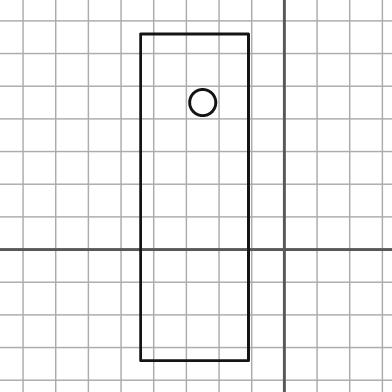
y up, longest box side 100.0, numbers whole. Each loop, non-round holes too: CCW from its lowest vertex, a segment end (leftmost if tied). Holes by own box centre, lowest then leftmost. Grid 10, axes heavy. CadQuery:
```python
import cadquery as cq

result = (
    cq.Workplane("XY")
    .moveTo(-44.0, -34.0)
    .lineTo(-11.0, -34.0)
    .lineTo(-11.0, 66.0)
    .lineTo(-44.0, 66.0)
    .close()
    .moveTo(-25.0, 45.0)
    .circle(4.0)
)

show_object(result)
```